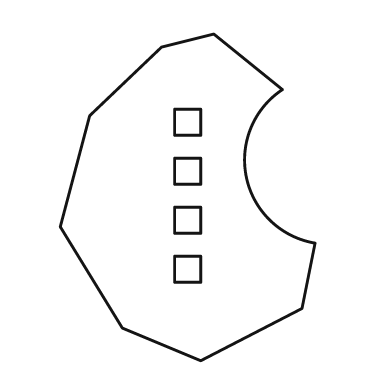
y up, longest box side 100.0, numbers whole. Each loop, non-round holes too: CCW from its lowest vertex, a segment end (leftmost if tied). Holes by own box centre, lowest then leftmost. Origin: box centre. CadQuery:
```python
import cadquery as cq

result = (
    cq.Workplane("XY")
    .moveTo(4.0, -50.0)
    .lineTo(35.0, -34.0)
    .lineTo(39.0, -14.0)
    .threePointArc((18.0, 6.0), (29.0, 33.0))
    .lineTo(8.0, 50.0)
    .lineTo(-8.0, 46.0)
    .lineTo(-30.0, 25.0)
    .lineTo(-39.0, -9.0)
    .lineTo(-20.0, -40.0)
    .close()
    .moveTo(-4.0, -26.0)
    .lineTo(4.0, -26.0)
    .lineTo(4.0, -18.0)
    .lineTo(-4.0, -18.0)
    .close()
    .moveTo(-4.0, -11.0)
    .lineTo(4.0, -11.0)
    .lineTo(4.0, -3.0)
    .lineTo(-4.0, -3.0)
    .close()
    .moveTo(-4.0, 4.0)
    .lineTo(4.0, 4.0)
    .lineTo(4.0, 12.0)
    .lineTo(-4.0, 12.0)
    .close()
    .moveTo(-4.0, 19.0)
    .lineTo(4.0, 19.0)
    .lineTo(4.0, 27.0)
    .lineTo(-4.0, 27.0)
    .close()
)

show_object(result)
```